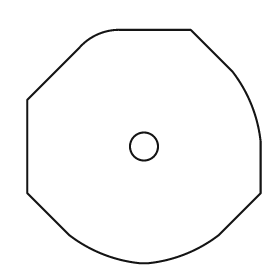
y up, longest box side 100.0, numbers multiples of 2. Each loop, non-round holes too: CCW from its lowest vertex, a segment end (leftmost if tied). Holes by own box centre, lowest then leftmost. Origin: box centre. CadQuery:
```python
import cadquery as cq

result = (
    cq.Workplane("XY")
    .moveTo(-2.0, -50.0)
    .lineTo(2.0, -50.0)
    .threePointArc((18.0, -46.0), (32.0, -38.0))
    .lineTo(50.0, -20.0)
    .lineTo(50.0, 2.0)
    .threePointArc((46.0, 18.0), (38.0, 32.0))
    .lineTo(20.0, 50.0)
    .lineTo(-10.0, 50.0)
    .threePointArc((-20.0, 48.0), (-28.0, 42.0))
    .lineTo(-50.0, 20.0)
    .lineTo(-50.0, -20.0)
    .lineTo(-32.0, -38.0)
    .threePointArc((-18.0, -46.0), (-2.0, -50.0))
    .close()
    .moveTo(0.0, 0.0)
    .circle(6.0)
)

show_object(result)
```